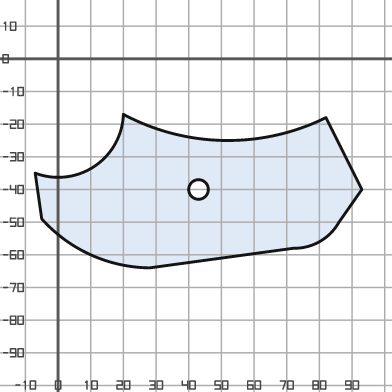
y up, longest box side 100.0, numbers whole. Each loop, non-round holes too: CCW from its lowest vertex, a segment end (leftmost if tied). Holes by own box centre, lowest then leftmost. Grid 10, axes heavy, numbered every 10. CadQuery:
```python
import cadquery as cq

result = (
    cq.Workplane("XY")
    .moveTo(28.0, -64.0)
    .lineTo(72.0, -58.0)
    .threePointArc((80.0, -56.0), (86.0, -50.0))
    .lineTo(93.0, -40.0)
    .lineTo(82.0, -18.0)
    .threePointArc((51.0, -25.0), (20.0, -17.0))
    .threePointArc((11.0, -33.0), (-7.0, -35.0))
    .lineTo(-5.0, -49.0)
    .threePointArc((10.0, -60.0), (28.0, -64.0))
    .close()
    .moveTo(43.0, -40.0)
    .circle(3.0)
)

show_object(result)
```